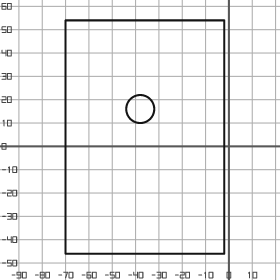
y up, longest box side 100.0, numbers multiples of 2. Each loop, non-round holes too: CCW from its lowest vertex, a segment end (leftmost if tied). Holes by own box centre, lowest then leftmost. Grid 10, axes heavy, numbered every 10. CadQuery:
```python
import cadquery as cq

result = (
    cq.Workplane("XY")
    .moveTo(-70.0, -46.0)
    .lineTo(-2.0, -46.0)
    .lineTo(-2.0, 54.0)
    .lineTo(-70.0, 54.0)
    .close()
    .moveTo(-38.0, 16.0)
    .circle(6.0)
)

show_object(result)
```